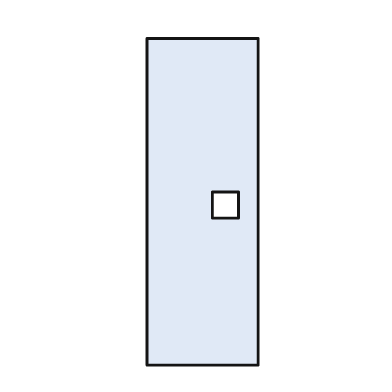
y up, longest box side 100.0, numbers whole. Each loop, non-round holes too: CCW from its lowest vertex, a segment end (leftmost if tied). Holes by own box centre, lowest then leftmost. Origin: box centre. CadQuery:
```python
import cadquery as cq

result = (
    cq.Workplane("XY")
    .moveTo(-17.0, -50.0)
    .lineTo(17.0, -50.0)
    .lineTo(17.0, 50.0)
    .lineTo(-17.0, 50.0)
    .close()
    .moveTo(3.0, -5.0)
    .lineTo(11.0, -5.0)
    .lineTo(11.0, 3.0)
    .lineTo(3.0, 3.0)
    .close()
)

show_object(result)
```